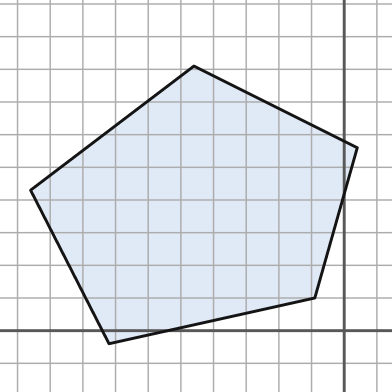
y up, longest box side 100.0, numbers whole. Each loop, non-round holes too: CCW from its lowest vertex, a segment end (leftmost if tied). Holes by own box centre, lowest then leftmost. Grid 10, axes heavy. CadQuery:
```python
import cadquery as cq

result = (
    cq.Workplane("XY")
    .moveTo(-72.0, -4.0)
    .lineTo(-9.0, 10.0)
    .lineTo(4.0, 56.0)
    .lineTo(-46.0, 81.0)
    .lineTo(-96.0, 43.0)
    .close()
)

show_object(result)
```